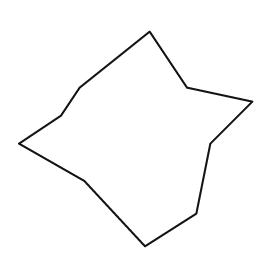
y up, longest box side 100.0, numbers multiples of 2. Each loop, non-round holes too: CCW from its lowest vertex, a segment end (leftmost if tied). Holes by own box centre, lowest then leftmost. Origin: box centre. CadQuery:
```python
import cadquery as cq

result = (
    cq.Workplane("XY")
    .moveTo(4.0, -46.0)
    .lineTo(26.0, -32.0)
    .lineTo(32.0, -2.0)
    .lineTo(50.0, 16.0)
    .lineTo(22.0, 22.0)
    .lineTo(6.0, 46.0)
    .lineTo(-24.0, 22.0)
    .lineTo(-32.0, 10.0)
    .lineTo(-50.0, -2.0)
    .lineTo(-22.0, -18.0)
    .close()
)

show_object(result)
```